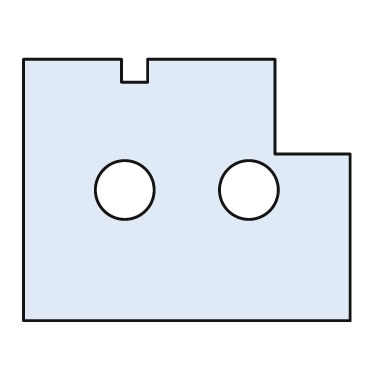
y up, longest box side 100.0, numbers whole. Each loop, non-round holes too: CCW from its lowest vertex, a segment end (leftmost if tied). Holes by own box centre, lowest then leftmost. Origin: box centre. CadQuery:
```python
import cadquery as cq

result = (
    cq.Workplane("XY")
    .moveTo(-50.0, -40.0)
    .lineTo(50.0, -40.0)
    .lineTo(50.0, 11.0)
    .lineTo(27.0, 11.0)
    .lineTo(27.0, 40.0)
    .lineTo(-12.0, 40.0)
    .lineTo(-12.0, 33.0)
    .lineTo(-20.0, 33.0)
    .lineTo(-20.0, 40.0)
    .lineTo(-50.0, 40.0)
    .close()
    .moveTo(-19.0, 0.0)
    .circle(9.0)
    .moveTo(19.0, 0.0)
    .circle(9.0)
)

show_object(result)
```